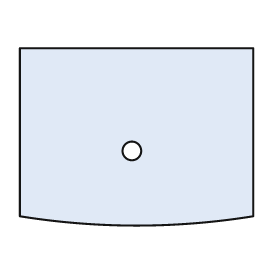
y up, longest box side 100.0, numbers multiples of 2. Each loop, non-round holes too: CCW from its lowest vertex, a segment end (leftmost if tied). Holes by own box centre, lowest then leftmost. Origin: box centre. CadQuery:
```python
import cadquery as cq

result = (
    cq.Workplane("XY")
    .moveTo(-50.0, -34.0)
    .threePointArc((0.0, -38.0), (50.0, -34.0))
    .lineTo(50.0, 38.0)
    .lineTo(-50.0, 38.0)
    .close()
    .moveTo(-2.0, -6.0)
    .circle(4.0)
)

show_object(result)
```